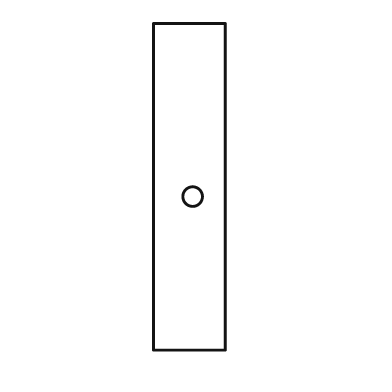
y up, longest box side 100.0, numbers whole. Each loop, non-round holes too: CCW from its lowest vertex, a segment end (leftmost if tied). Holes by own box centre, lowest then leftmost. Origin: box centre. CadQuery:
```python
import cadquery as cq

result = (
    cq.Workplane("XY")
    .moveTo(-11.0, -50.0)
    .lineTo(11.0, -50.0)
    .lineTo(11.0, 50.0)
    .lineTo(-11.0, 50.0)
    .close()
    .moveTo(1.0, -3.0)
    .circle(3.0)
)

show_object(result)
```